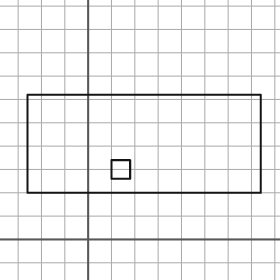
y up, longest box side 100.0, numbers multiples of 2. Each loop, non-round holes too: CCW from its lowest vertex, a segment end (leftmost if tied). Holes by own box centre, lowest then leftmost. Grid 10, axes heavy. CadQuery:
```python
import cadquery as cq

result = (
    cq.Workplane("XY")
    .moveTo(-26.0, 20.0)
    .lineTo(74.0, 20.0)
    .lineTo(74.0, 62.0)
    .lineTo(-26.0, 62.0)
    .close()
    .moveTo(10.0, 26.0)
    .lineTo(18.0, 26.0)
    .lineTo(18.0, 34.0)
    .lineTo(10.0, 34.0)
    .close()
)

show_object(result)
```